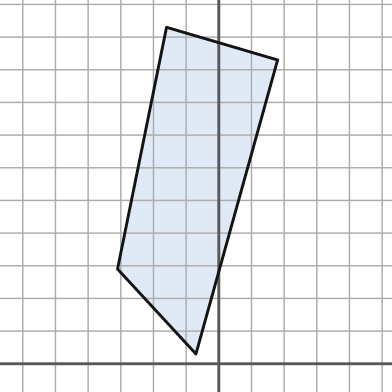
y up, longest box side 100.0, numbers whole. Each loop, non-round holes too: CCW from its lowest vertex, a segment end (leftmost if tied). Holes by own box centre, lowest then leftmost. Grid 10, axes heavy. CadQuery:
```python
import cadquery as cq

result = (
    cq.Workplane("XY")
    .moveTo(-7.0, 3.0)
    .lineTo(18.0, 93.0)
    .lineTo(-16.0, 103.0)
    .lineTo(-31.0, 29.0)
    .close()
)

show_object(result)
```